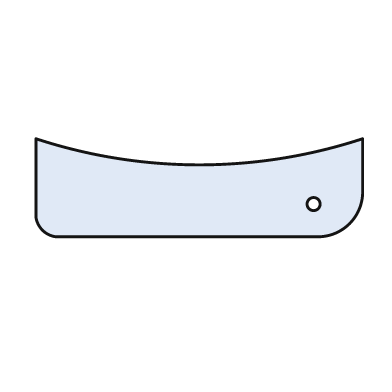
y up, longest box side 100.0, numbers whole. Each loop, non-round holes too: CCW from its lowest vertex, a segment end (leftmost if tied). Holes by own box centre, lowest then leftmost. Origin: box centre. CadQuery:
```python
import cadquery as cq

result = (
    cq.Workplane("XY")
    .moveTo(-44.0, -15.0)
    .lineTo(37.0, -15.0)
    .threePointArc((46.0, -11.0), (50.0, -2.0))
    .lineTo(50.0, 15.0)
    .threePointArc((0.0, 7.0), (-50.0, 15.0))
    .lineTo(-50.0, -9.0)
    .threePointArc((-48.0, -13.0), (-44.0, -15.0))
    .close()
    .moveTo(35.0, -5.0)
    .circle(2.0)
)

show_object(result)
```